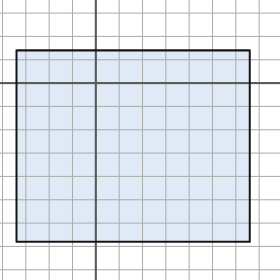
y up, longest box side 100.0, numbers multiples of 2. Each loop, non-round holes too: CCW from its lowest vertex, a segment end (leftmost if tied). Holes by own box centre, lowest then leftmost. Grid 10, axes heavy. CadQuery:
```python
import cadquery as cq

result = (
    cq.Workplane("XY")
    .moveTo(-34.0, -68.0)
    .lineTo(66.0, -68.0)
    .lineTo(66.0, 14.0)
    .lineTo(-34.0, 14.0)
    .close()
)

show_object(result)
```